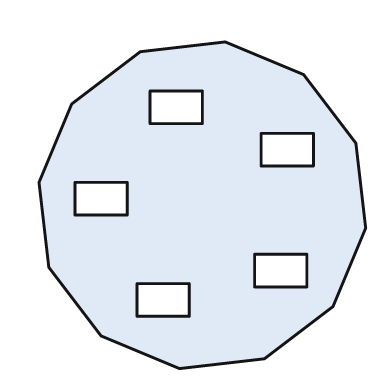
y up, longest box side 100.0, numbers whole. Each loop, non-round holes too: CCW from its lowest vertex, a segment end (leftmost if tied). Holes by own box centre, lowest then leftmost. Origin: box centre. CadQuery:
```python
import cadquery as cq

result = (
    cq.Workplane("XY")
    .moveTo(-7.0, -50.0)
    .lineTo(19.0, -47.0)
    .lineTo(40.0, -31.0)
    .lineTo(50.0, -7.0)
    .lineTo(47.0, 19.0)
    .lineTo(31.0, 40.0)
    .lineTo(7.0, 50.0)
    .lineTo(-19.0, 47.0)
    .lineTo(-40.0, 31.0)
    .lineTo(-50.0, 7.0)
    .lineTo(-47.0, -19.0)
    .lineTo(-31.0, -40.0)
    .close()
    .moveTo(-20.0, -34.0)
    .lineTo(-4.0, -34.0)
    .lineTo(-4.0, -24.0)
    .lineTo(-20.0, -24.0)
    .close()
    .moveTo(16.0, -25.0)
    .lineTo(32.0, -25.0)
    .lineTo(32.0, -15.0)
    .lineTo(16.0, -15.0)
    .close()
    .moveTo(-39.0, -3.0)
    .lineTo(-23.0, -3.0)
    .lineTo(-23.0, 7.0)
    .lineTo(-39.0, 7.0)
    .close()
    .moveTo(18.0, 12.0)
    .lineTo(34.0, 12.0)
    .lineTo(34.0, 22.0)
    .lineTo(18.0, 22.0)
    .close()
    .moveTo(-16.0, 25.0)
    .lineTo(0.0, 25.0)
    .lineTo(0.0, 35.0)
    .lineTo(-16.0, 35.0)
    .close()
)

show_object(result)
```